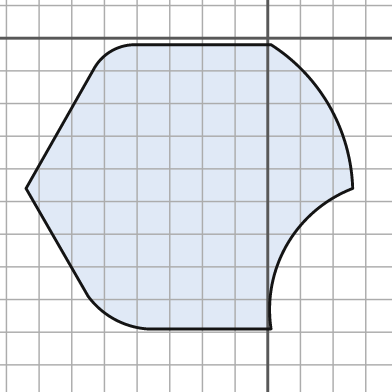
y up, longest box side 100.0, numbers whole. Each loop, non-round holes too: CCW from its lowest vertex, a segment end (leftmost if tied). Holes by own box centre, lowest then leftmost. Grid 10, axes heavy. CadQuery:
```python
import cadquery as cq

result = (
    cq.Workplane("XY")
    .moveTo(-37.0, -89.0)
    .lineTo(1.0, -89.0)
    .threePointArc((6.0, -63.0), (26.0, -46.0))
    .threePointArc((19.0, -21.0), (1.0, -2.0))
    .lineTo(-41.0, -2.0)
    .threePointArc((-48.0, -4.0), (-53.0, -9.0))
    .lineTo(-74.0, -46.0)
    .lineTo(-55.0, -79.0)
    .threePointArc((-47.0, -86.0), (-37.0, -89.0))
    .close()
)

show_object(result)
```